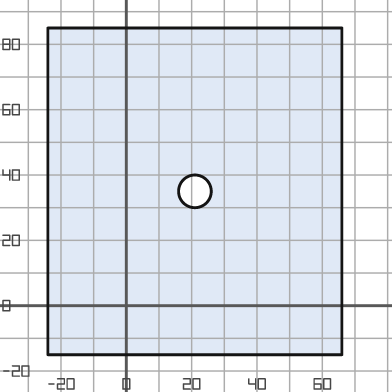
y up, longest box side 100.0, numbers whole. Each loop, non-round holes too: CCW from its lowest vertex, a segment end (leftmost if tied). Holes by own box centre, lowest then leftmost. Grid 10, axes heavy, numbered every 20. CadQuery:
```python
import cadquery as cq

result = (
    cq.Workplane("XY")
    .moveTo(-24.0, -15.0)
    .lineTo(66.0, -15.0)
    .lineTo(66.0, 85.0)
    .lineTo(-24.0, 85.0)
    .close()
    .moveTo(21.0, 35.0)
    .circle(5.0)
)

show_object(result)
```